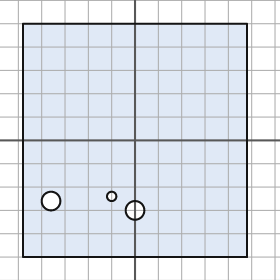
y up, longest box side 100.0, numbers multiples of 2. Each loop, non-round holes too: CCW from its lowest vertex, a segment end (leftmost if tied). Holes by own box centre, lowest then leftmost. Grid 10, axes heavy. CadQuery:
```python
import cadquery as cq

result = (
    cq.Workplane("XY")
    .moveTo(-48.0, -50.0)
    .lineTo(48.0, -50.0)
    .lineTo(48.0, 50.0)
    .lineTo(-48.0, 50.0)
    .close()
    .moveTo(0.0, -30.0)
    .circle(4.0)
    .moveTo(-36.0, -26.0)
    .circle(4.0)
    .moveTo(-10.0, -24.0)
    .circle(2.0)
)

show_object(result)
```